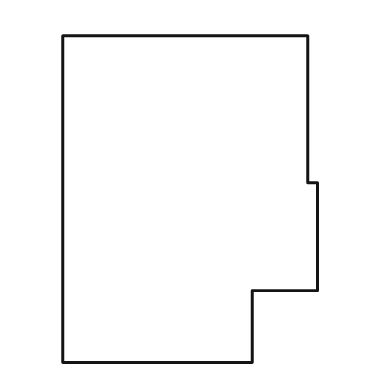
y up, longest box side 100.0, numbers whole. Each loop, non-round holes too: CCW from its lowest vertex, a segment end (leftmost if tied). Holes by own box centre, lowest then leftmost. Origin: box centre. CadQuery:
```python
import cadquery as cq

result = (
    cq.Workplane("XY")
    .moveTo(-39.0, -50.0)
    .lineTo(19.0, -50.0)
    .lineTo(19.0, -28.0)
    .lineTo(39.0, -28.0)
    .lineTo(39.0, 5.0)
    .lineTo(36.0, 5.0)
    .lineTo(36.0, 50.0)
    .lineTo(-39.0, 50.0)
    .close()
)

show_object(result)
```